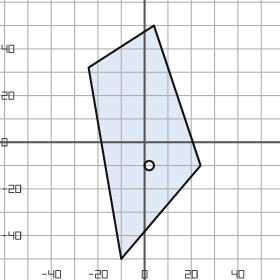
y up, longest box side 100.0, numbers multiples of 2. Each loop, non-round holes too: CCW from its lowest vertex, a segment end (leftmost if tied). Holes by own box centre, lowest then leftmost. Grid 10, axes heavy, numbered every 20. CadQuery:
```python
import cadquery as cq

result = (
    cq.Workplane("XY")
    .moveTo(-10.0, -50.0)
    .lineTo(24.0, -10.0)
    .lineTo(4.0, 50.0)
    .lineTo(-24.0, 32.0)
    .close()
    .moveTo(2.0, -10.0)
    .circle(2.0)
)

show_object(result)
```